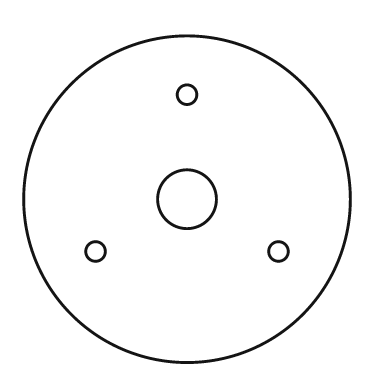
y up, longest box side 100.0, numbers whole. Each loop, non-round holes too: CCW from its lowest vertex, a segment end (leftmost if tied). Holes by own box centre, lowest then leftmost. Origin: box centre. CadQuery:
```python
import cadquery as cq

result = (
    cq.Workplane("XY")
    .moveTo(0.0, 0.0)
    .circle(50.0)
    .moveTo(-28.0, -16.0)
    .circle(3.0)
    .moveTo(28.0, -16.0)
    .circle(3.0)
    .moveTo(0.0, 0.0)
    .circle(9.0)
    .moveTo(0.0, 32.0)
    .circle(3.0)
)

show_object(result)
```